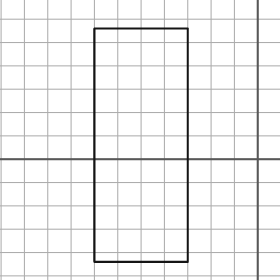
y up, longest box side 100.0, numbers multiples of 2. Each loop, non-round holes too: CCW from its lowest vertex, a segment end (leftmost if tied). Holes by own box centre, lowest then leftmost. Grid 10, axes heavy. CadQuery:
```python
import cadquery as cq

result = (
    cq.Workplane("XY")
    .moveTo(-70.0, -44.0)
    .lineTo(-30.0, -44.0)
    .lineTo(-30.0, 56.0)
    .lineTo(-70.0, 56.0)
    .close()
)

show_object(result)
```